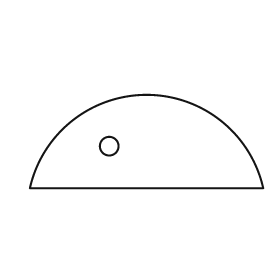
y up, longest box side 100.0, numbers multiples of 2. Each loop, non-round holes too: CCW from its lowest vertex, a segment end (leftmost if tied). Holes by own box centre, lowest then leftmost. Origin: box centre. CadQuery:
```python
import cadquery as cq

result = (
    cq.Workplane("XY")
    .moveTo(-50.0, -20.0)
    .lineTo(50.0, -20.0)
    .threePointArc((0.0, 20.0), (-50.0, -20.0))
    .close()
    .moveTo(-16.0, -2.0)
    .circle(4.0)
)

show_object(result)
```